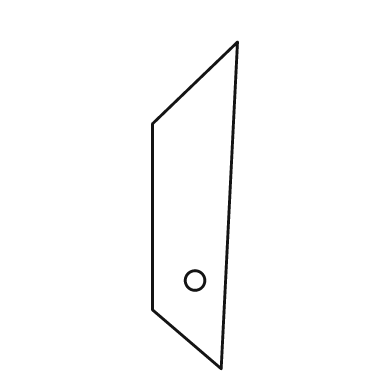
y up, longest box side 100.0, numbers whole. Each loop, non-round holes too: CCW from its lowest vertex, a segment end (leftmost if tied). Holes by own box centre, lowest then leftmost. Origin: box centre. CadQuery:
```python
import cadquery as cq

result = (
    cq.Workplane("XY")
    .moveTo(8.0, -50.0)
    .lineTo(13.0, 50.0)
    .lineTo(-13.0, 25.0)
    .lineTo(-13.0, -32.0)
    .close()
    .moveTo(0.0, -23.0)
    .circle(3.0)
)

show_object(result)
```